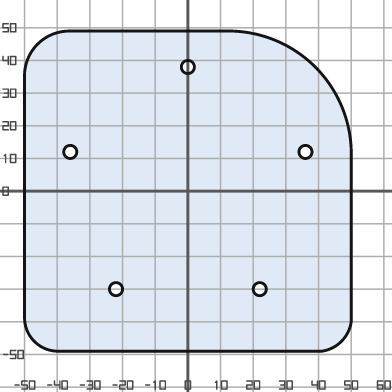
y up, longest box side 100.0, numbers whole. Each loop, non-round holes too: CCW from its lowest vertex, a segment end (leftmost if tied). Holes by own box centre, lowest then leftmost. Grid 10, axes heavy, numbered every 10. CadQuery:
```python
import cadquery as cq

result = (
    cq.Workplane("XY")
    .moveTo(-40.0, -49.0)
    .lineTo(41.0, -49.0)
    .threePointArc((47.0, -46.0), (50.0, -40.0))
    .lineTo(50.0, 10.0)
    .threePointArc((39.0, 38.0), (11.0, 49.0))
    .lineTo(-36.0, 49.0)
    .threePointArc((-46.0, 45.0), (-50.0, 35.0))
    .lineTo(-50.0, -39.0)
    .threePointArc((-47.0, -46.0), (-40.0, -49.0))
    .close()
    .moveTo(-22.0, -30.0)
    .circle(2.0)
    .moveTo(22.0, -30.0)
    .circle(2.0)
    .moveTo(-36.0, 12.0)
    .circle(2.0)
    .moveTo(36.0, 12.0)
    .circle(2.0)
    .moveTo(0.0, 38.0)
    .circle(2.0)
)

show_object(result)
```